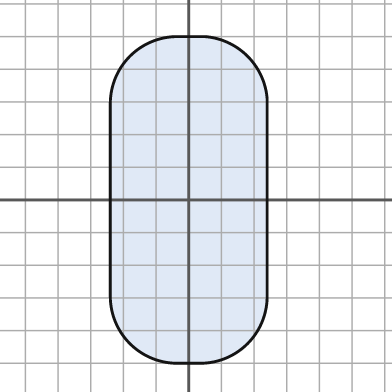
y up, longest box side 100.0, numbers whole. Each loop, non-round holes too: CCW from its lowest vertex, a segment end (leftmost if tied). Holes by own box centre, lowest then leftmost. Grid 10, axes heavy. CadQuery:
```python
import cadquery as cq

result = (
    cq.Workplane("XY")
    .moveTo(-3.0, -50.0)
    .lineTo(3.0, -50.0)
    .threePointArc((18.0, -44.0), (24.0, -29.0))
    .lineTo(24.0, 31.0)
    .threePointArc((18.0, 44.0), (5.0, 50.0))
    .lineTo(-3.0, 50.0)
    .threePointArc((-18.0, 44.0), (-24.0, 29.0))
    .lineTo(-24.0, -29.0)
    .threePointArc((-18.0, -44.0), (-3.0, -50.0))
    .close()
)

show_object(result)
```